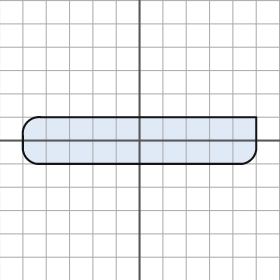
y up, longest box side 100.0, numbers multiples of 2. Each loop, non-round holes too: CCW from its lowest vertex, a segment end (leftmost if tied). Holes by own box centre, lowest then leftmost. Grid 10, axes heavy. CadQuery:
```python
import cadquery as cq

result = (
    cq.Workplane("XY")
    .moveTo(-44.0, -10.0)
    .lineTo(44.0, -10.0)
    .threePointArc((48.0, -8.0), (50.0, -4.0))
    .lineTo(50.0, 10.0)
    .lineTo(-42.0, 10.0)
    .threePointArc((-48.0, 8.0), (-50.0, 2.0))
    .lineTo(-50.0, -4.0)
    .threePointArc((-48.0, -8.0), (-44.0, -10.0))
    .close()
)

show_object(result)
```